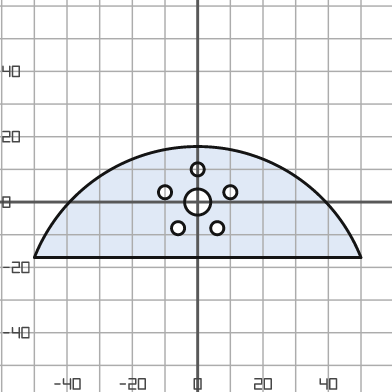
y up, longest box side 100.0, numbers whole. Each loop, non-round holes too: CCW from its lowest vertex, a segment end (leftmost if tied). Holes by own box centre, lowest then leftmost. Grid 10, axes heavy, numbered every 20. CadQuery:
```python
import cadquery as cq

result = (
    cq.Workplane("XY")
    .moveTo(-50.0, -17.0)
    .lineTo(50.0, -17.0)
    .threePointArc((0.0, 17.0), (-50.0, -17.0))
    .close()
    .moveTo(-6.0, -8.0)
    .circle(2.0)
    .moveTo(6.0, -8.0)
    .circle(2.0)
    .moveTo(0.0, 0.0)
    .circle(4.0)
    .moveTo(-10.0, 3.0)
    .circle(2.0)
    .moveTo(10.0, 3.0)
    .circle(2.0)
    .moveTo(0.0, 10.0)
    .circle(2.0)
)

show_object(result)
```